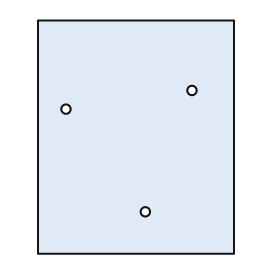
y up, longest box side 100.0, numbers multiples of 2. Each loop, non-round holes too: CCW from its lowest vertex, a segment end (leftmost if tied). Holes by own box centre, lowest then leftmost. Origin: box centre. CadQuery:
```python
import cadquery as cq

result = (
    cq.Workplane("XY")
    .moveTo(-42.0, -50.0)
    .lineTo(42.0, -50.0)
    .lineTo(42.0, 50.0)
    .lineTo(-42.0, 50.0)
    .close()
    .moveTo(4.0, -32.0)
    .circle(2.0)
    .moveTo(-30.0, 12.0)
    .circle(2.0)
    .moveTo(24.0, 20.0)
    .circle(2.0)
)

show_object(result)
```